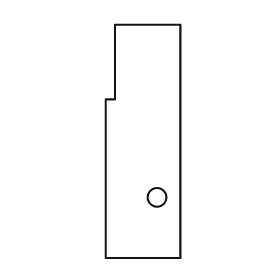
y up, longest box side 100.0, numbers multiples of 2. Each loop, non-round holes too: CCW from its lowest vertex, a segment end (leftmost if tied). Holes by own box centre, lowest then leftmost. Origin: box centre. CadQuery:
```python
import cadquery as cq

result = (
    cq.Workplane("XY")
    .moveTo(-16.0, -50.0)
    .lineTo(16.0, -50.0)
    .lineTo(16.0, 50.0)
    .lineTo(-12.0, 50.0)
    .lineTo(-12.0, 18.0)
    .lineTo(-16.0, 18.0)
    .close()
    .moveTo(6.0, -24.0)
    .circle(4.0)
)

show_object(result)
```